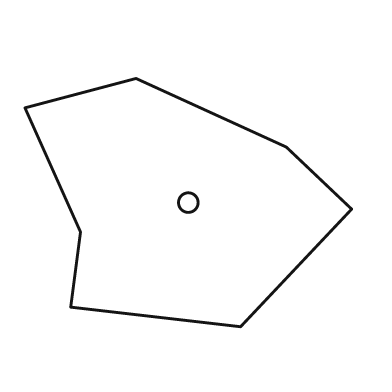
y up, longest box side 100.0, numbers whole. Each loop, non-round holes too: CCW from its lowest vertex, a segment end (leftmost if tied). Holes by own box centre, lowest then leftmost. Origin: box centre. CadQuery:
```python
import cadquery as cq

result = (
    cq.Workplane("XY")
    .moveTo(16.0, -38.0)
    .lineTo(50.0, -2.0)
    .lineTo(30.0, 17.0)
    .lineTo(-16.0, 38.0)
    .lineTo(-50.0, 29.0)
    .lineTo(-33.0, -9.0)
    .lineTo(-36.0, -32.0)
    .close()
    .moveTo(0.0, 0.0)
    .circle(3.0)
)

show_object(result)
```